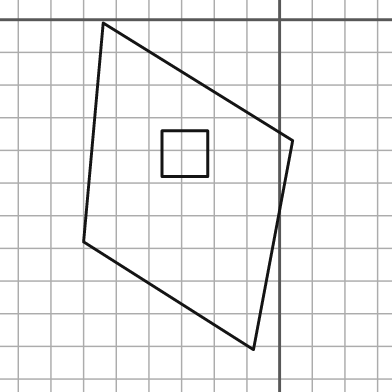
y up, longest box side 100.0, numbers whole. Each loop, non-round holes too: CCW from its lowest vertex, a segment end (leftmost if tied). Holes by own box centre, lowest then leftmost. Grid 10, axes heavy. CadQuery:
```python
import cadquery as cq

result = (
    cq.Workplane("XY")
    .moveTo(-8.0, -101.0)
    .lineTo(4.0, -37.0)
    .lineTo(-54.0, -1.0)
    .lineTo(-60.0, -68.0)
    .close()
    .moveTo(-36.0, -48.0)
    .lineTo(-22.0, -48.0)
    .lineTo(-22.0, -34.0)
    .lineTo(-36.0, -34.0)
    .close()
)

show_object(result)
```